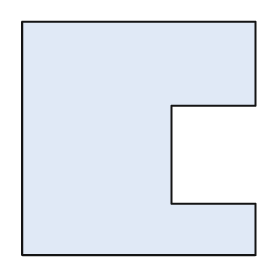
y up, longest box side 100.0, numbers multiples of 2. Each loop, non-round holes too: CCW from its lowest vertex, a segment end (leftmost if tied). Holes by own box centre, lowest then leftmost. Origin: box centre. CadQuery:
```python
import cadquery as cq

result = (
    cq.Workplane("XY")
    .moveTo(-50.0, -50.0)
    .lineTo(50.0, -50.0)
    .lineTo(50.0, -28.0)
    .lineTo(14.0, -28.0)
    .lineTo(14.0, 14.0)
    .lineTo(50.0, 14.0)
    .lineTo(50.0, 50.0)
    .lineTo(-50.0, 50.0)
    .close()
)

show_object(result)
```